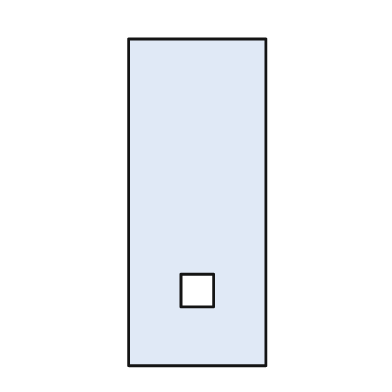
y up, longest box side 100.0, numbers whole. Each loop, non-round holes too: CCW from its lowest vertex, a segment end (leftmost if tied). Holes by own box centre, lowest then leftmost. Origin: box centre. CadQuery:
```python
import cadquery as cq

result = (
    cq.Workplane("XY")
    .moveTo(-21.0, -50.0)
    .lineTo(21.0, -50.0)
    .lineTo(21.0, 50.0)
    .lineTo(-21.0, 50.0)
    .close()
    .moveTo(-5.0, -32.0)
    .lineTo(5.0, -32.0)
    .lineTo(5.0, -22.0)
    .lineTo(-5.0, -22.0)
    .close()
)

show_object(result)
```